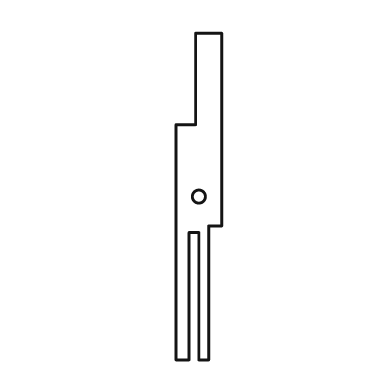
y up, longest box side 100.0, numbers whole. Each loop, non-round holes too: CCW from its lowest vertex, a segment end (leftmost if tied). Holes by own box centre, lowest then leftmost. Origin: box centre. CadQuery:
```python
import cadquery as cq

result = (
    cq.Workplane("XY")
    .moveTo(-7.0, -50.0)
    .lineTo(-3.0, -50.0)
    .lineTo(-3.0, -11.0)
    .lineTo(0.0, -11.0)
    .lineTo(0.0, -50.0)
    .lineTo(3.0, -50.0)
    .lineTo(3.0, -9.0)
    .lineTo(7.0, -9.0)
    .lineTo(7.0, 50.0)
    .lineTo(-1.0, 50.0)
    .lineTo(-1.0, 22.0)
    .lineTo(-7.0, 22.0)
    .close()
    .moveTo(0.0, 0.0)
    .circle(2.0)
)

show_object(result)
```